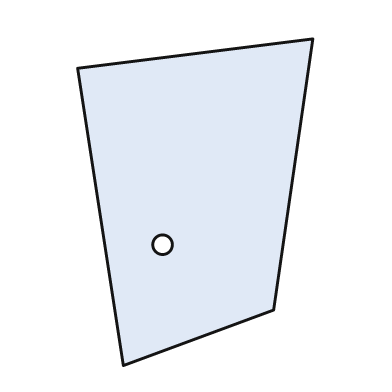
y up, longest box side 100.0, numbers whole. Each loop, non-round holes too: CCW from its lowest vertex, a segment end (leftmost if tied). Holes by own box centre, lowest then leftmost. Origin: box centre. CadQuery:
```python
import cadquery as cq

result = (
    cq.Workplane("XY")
    .moveTo(-22.0, -50.0)
    .lineTo(24.0, -33.0)
    .lineTo(36.0, 50.0)
    .lineTo(-36.0, 41.0)
    .close()
    .moveTo(-10.0, -13.0)
    .circle(3.0)
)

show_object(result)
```